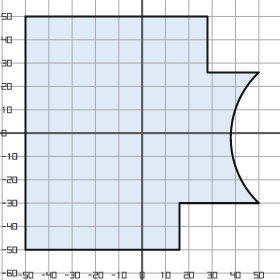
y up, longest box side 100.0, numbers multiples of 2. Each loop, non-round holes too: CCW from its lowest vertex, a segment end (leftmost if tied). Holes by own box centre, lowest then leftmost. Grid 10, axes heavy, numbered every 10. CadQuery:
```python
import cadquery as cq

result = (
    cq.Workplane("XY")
    .moveTo(-50.0, -50.0)
    .lineTo(16.0, -50.0)
    .lineTo(16.0, -30.0)
    .lineTo(50.0, -30.0)
    .threePointArc((38.0, -2.0), (50.0, 26.0))
    .lineTo(28.0, 26.0)
    .lineTo(28.0, 50.0)
    .lineTo(-50.0, 50.0)
    .close()
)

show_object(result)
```